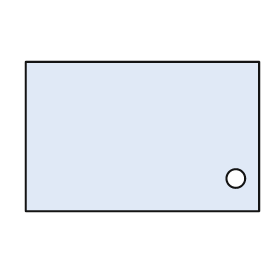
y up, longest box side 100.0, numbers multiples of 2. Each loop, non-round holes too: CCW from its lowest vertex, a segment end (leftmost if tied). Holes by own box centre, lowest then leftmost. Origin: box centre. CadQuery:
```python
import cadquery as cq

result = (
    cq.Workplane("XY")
    .moveTo(-50.0, -32.0)
    .lineTo(50.0, -32.0)
    .lineTo(50.0, 32.0)
    .lineTo(-50.0, 32.0)
    .close()
    .moveTo(40.0, -18.0)
    .circle(4.0)
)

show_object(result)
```